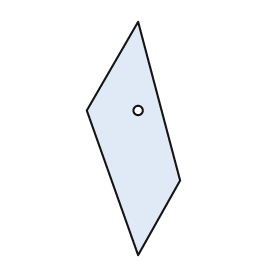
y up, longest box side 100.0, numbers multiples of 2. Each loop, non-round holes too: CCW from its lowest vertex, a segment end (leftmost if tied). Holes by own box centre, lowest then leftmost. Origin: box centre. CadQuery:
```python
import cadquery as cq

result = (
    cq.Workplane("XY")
    .moveTo(2.0, -50.0)
    .lineTo(20.0, -18.0)
    .lineTo(2.0, 50.0)
    .lineTo(-20.0, 12.0)
    .close()
    .moveTo(2.0, 12.0)
    .circle(2.0)
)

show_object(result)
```